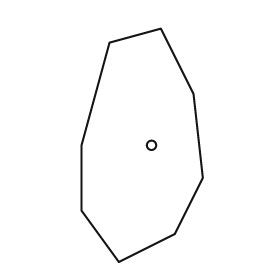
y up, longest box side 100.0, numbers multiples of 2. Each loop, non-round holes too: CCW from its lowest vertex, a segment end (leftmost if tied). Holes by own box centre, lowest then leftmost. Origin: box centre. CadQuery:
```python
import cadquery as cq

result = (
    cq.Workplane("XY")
    .moveTo(-10.0, -50.0)
    .lineTo(14.0, -38.0)
    .lineTo(26.0, -14.0)
    .lineTo(22.0, 22.0)
    .lineTo(8.0, 50.0)
    .lineTo(-14.0, 44.0)
    .lineTo(-26.0, 0.0)
    .lineTo(-26.0, -28.0)
    .close()
    .moveTo(4.0, 0.0)
    .circle(2.0)
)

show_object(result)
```